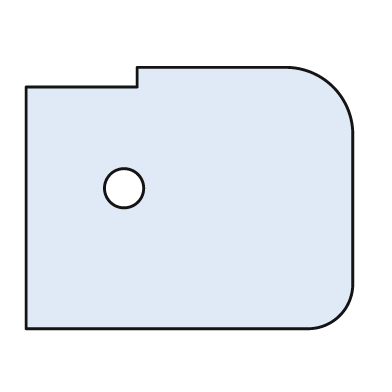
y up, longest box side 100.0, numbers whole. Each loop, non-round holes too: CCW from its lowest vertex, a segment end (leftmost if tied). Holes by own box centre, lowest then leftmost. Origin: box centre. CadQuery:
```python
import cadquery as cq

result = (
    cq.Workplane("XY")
    .moveTo(-50.0, -40.0)
    .lineTo(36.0, -40.0)
    .threePointArc((46.0, -36.0), (50.0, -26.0))
    .lineTo(50.0, 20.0)
    .threePointArc((44.0, 34.0), (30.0, 40.0))
    .lineTo(-16.0, 40.0)
    .lineTo(-16.0, 34.0)
    .lineTo(-50.0, 34.0)
    .close()
    .moveTo(-20.0, 3.0)
    .circle(6.0)
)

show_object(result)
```